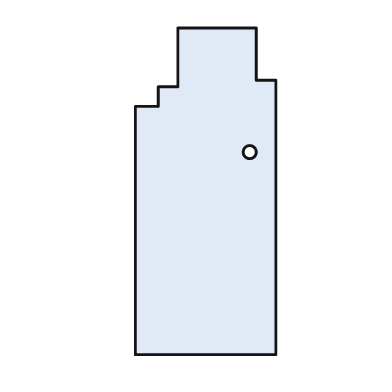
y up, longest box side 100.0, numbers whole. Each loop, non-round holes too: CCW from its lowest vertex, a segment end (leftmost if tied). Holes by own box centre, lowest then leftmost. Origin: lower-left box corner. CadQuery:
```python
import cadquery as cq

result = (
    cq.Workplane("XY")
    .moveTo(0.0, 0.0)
    .lineTo(43.0, 0.0)
    .lineTo(43.0, 84.0)
    .lineTo(37.0, 84.0)
    .lineTo(37.0, 100.0)
    .lineTo(13.0, 100.0)
    .lineTo(13.0, 82.0)
    .lineTo(7.0, 82.0)
    .lineTo(7.0, 76.0)
    .lineTo(0.0, 76.0)
    .close()
    .moveTo(35.0, 62.0)
    .circle(2.0)
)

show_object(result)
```